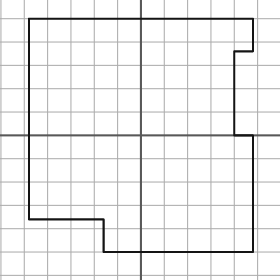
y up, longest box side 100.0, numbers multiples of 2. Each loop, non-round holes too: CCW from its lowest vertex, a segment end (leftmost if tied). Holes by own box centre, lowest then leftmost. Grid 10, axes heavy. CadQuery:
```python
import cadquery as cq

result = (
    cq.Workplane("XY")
    .moveTo(-16.0, -50.0)
    .lineTo(48.0, -50.0)
    .lineTo(48.0, 0.0)
    .lineTo(40.0, 0.0)
    .lineTo(40.0, 36.0)
    .lineTo(48.0, 36.0)
    .lineTo(48.0, 50.0)
    .lineTo(-48.0, 50.0)
    .lineTo(-48.0, -36.0)
    .lineTo(-16.0, -36.0)
    .close()
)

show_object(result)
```